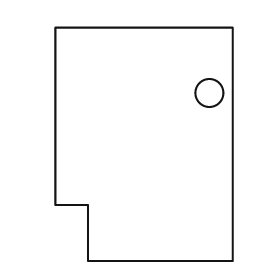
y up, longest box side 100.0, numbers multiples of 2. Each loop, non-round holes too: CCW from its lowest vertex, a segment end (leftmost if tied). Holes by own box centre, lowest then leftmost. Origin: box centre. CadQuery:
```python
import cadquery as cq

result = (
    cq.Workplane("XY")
    .moveTo(-24.0, -50.0)
    .lineTo(38.0, -50.0)
    .lineTo(38.0, 50.0)
    .lineTo(-38.0, 50.0)
    .lineTo(-38.0, -26.0)
    .lineTo(-24.0, -26.0)
    .close()
    .moveTo(28.0, 22.0)
    .circle(6.0)
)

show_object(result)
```